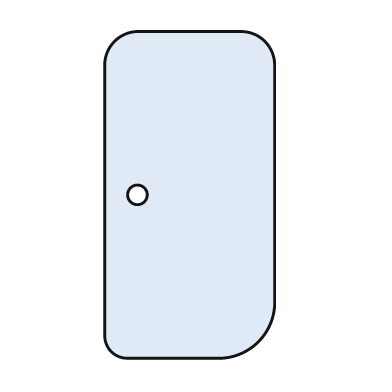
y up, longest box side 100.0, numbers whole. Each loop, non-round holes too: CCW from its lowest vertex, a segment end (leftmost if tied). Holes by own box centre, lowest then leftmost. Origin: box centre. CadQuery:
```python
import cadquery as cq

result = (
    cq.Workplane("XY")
    .moveTo(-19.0, -50.0)
    .lineTo(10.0, -50.0)
    .threePointArc((21.0, -45.0), (26.0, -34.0))
    .lineTo(26.0, 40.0)
    .threePointArc((23.0, 47.0), (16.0, 50.0))
    .lineTo(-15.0, 50.0)
    .threePointArc((-23.0, 47.0), (-26.0, 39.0))
    .lineTo(-26.0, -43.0)
    .threePointArc((-24.0, -48.0), (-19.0, -50.0))
    .close()
    .moveTo(-16.0, 0.0)
    .circle(3.0)
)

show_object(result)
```